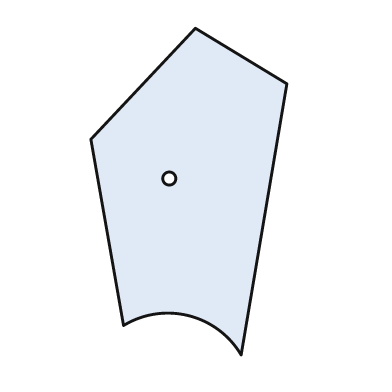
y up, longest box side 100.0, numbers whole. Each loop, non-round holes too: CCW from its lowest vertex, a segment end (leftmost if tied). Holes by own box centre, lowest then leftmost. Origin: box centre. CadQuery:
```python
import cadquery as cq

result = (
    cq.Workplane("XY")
    .moveTo(16.0, -50.0)
    .lineTo(30.0, 33.0)
    .lineTo(2.0, 50.0)
    .lineTo(-30.0, 16.0)
    .lineTo(-20.0, -41.0)
    .threePointArc((0.0, -38.0), (16.0, -50.0))
    .close()
    .moveTo(-6.0, 4.0)
    .circle(2.0)
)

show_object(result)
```